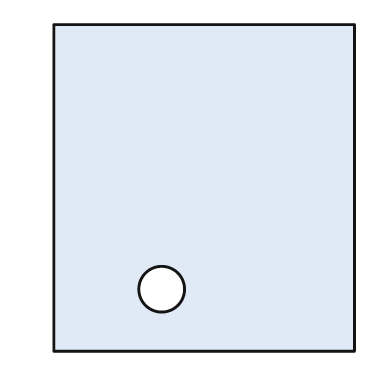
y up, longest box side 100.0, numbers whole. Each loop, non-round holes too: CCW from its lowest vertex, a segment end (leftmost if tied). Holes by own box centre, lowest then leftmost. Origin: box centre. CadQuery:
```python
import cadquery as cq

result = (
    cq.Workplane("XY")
    .moveTo(-46.0, -50.0)
    .lineTo(46.0, -50.0)
    .lineTo(46.0, 50.0)
    .lineTo(-46.0, 50.0)
    .close()
    .moveTo(-13.0, -31.0)
    .circle(7.0)
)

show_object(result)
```